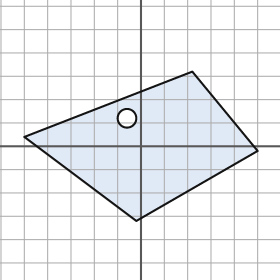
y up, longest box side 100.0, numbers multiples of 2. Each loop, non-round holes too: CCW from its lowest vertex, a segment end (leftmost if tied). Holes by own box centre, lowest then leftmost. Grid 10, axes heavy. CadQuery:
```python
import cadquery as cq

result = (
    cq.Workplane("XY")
    .moveTo(-2.0, -32.0)
    .lineTo(50.0, -2.0)
    .lineTo(22.0, 32.0)
    .lineTo(-50.0, 4.0)
    .close()
    .moveTo(-6.0, 12.0)
    .circle(4.0)
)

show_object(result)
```